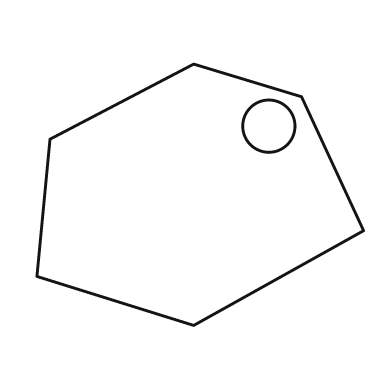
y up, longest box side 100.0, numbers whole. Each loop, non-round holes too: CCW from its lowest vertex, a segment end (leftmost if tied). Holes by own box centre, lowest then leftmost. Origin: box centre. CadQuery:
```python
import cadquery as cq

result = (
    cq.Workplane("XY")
    .moveTo(-2.0, -40.0)
    .lineTo(50.0, -11.0)
    .lineTo(31.0, 30.0)
    .lineTo(-2.0, 40.0)
    .lineTo(-46.0, 17.0)
    .lineTo(-50.0, -25.0)
    .close()
    .moveTo(21.0, 21.0)
    .circle(8.0)
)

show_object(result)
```